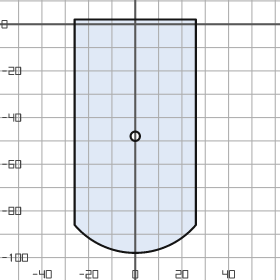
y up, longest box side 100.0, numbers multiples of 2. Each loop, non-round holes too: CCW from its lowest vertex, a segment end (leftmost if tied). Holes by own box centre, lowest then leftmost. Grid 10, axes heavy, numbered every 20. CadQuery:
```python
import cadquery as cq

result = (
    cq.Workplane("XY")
    .moveTo(-26.0, -86.0)
    .threePointArc((0.0, -98.0), (26.0, -86.0))
    .lineTo(26.0, 2.0)
    .lineTo(-26.0, 2.0)
    .close()
    .moveTo(0.0, -48.0)
    .circle(2.0)
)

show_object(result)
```